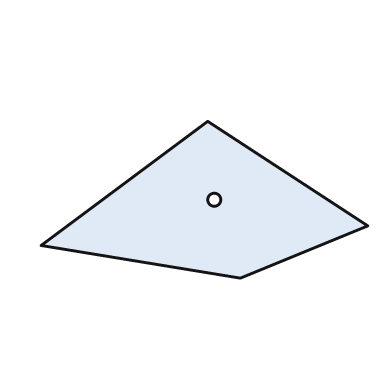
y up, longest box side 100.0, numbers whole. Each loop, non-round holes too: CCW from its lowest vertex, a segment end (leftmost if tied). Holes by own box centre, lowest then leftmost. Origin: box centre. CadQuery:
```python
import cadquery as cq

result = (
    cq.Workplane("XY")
    .moveTo(11.0, -24.0)
    .lineTo(50.0, -8.0)
    .lineTo(1.0, 24.0)
    .lineTo(-50.0, -14.0)
    .close()
    .moveTo(3.0, 0.0)
    .circle(2.0)
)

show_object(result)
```